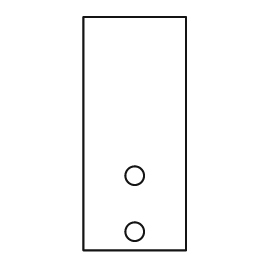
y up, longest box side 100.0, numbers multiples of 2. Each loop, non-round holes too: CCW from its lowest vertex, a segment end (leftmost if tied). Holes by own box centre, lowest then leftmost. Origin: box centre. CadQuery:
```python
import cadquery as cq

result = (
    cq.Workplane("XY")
    .moveTo(-22.0, -50.0)
    .lineTo(22.0, -50.0)
    .lineTo(22.0, 50.0)
    .lineTo(-22.0, 50.0)
    .close()
    .moveTo(0.0, -42.0)
    .circle(4.0)
    .moveTo(0.0, -18.0)
    .circle(4.0)
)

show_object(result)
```